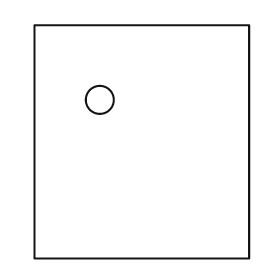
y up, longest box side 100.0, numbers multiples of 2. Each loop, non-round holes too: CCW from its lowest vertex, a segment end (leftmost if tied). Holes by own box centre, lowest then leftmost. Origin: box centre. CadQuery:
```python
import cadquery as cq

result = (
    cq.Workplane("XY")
    .moveTo(-46.0, -50.0)
    .lineTo(46.0, -50.0)
    .lineTo(46.0, 50.0)
    .lineTo(-46.0, 50.0)
    .close()
    .moveTo(-18.0, 18.0)
    .circle(6.0)
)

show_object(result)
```